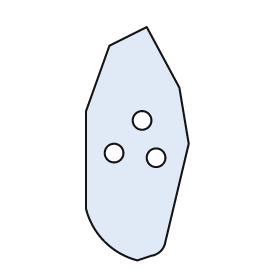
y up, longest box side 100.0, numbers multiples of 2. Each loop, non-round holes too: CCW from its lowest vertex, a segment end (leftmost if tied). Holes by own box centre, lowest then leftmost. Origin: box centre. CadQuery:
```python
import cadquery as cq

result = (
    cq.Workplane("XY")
    .moveTo(0.0, -50.0)
    .lineTo(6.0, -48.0)
    .threePointArc((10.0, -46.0), (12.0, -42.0))
    .lineTo(22.0, 0.0)
    .lineTo(18.0, 24.0)
    .lineTo(4.0, 50.0)
    .lineTo(-12.0, 42.0)
    .lineTo(-22.0, 14.0)
    .lineTo(-22.0, -28.0)
    .threePointArc((-14.0, -42.0), (0.0, -50.0))
    .close()
    .moveTo(8.0, -6.0)
    .circle(4.0)
    .moveTo(-10.0, -4.0)
    .circle(4.0)
    .moveTo(2.0, 10.0)
    .circle(4.0)
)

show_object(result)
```